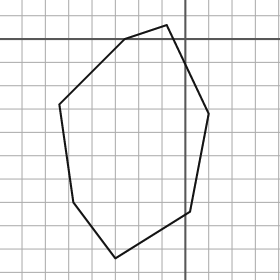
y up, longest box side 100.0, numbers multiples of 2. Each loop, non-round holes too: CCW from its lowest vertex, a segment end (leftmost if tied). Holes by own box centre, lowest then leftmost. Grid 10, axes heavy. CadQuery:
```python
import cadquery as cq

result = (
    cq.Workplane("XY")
    .moveTo(-30.0, -94.0)
    .lineTo(2.0, -74.0)
    .lineTo(10.0, -32.0)
    .lineTo(-8.0, 6.0)
    .lineTo(-26.0, 0.0)
    .lineTo(-54.0, -28.0)
    .lineTo(-48.0, -70.0)
    .close()
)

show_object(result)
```